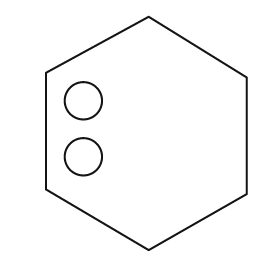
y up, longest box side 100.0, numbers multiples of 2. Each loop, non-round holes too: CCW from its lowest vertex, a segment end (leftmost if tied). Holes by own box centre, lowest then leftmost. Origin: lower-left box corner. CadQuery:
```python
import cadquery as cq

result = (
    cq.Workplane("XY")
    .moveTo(44.0, 0.0)
    .lineTo(86.0, 24.0)
    .lineTo(86.0, 74.0)
    .lineTo(44.0, 100.0)
    .lineTo(0.0, 76.0)
    .lineTo(0.0, 26.0)
    .close()
    .moveTo(16.0, 40.0)
    .circle(8.0)
    .moveTo(16.0, 64.0)
    .circle(8.0)
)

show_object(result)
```